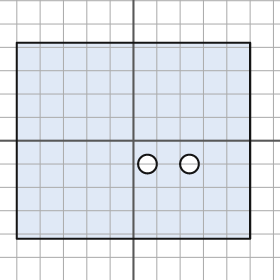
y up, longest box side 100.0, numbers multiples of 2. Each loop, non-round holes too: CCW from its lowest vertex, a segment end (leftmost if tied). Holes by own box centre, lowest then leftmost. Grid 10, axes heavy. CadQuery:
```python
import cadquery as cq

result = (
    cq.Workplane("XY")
    .moveTo(-50.0, -42.0)
    .lineTo(50.0, -42.0)
    .lineTo(50.0, 42.0)
    .lineTo(-50.0, 42.0)
    .close()
    .moveTo(6.0, -10.0)
    .circle(4.0)
    .moveTo(24.0, -10.0)
    .circle(4.0)
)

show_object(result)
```